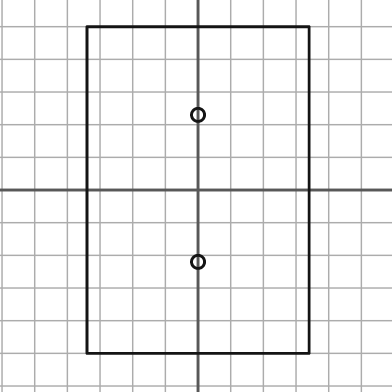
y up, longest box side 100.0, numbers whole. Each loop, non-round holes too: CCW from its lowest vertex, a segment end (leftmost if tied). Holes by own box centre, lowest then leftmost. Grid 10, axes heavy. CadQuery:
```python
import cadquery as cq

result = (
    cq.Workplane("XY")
    .moveTo(-34.0, -50.0)
    .lineTo(34.0, -50.0)
    .lineTo(34.0, 50.0)
    .lineTo(-34.0, 50.0)
    .close()
    .moveTo(0.0, -22.0)
    .circle(2.0)
    .moveTo(0.0, 23.0)
    .circle(2.0)
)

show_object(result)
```